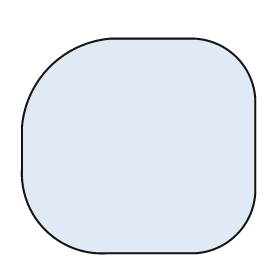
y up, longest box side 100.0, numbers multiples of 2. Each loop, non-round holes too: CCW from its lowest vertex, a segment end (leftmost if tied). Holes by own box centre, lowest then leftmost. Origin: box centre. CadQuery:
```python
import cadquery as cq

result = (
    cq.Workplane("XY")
    .moveTo(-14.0, -46.0)
    .lineTo(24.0, -46.0)
    .threePointArc((42.0, -38.0), (50.0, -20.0))
    .lineTo(50.0, 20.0)
    .threePointArc((42.0, 38.0), (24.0, 46.0))
    .lineTo(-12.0, 46.0)
    .threePointArc((-38.0, 34.0), (-50.0, 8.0))
    .lineTo(-50.0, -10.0)
    .threePointArc((-40.0, -36.0), (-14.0, -46.0))
    .close()
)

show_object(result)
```